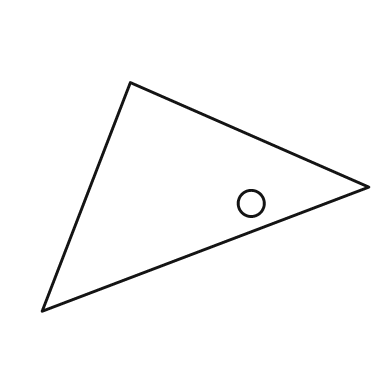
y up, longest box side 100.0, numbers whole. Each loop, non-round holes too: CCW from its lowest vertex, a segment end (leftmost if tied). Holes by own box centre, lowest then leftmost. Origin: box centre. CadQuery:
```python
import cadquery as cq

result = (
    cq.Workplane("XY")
    .moveTo(-50.0, -35.0)
    .lineTo(50.0, 3.0)
    .lineTo(-23.0, 35.0)
    .close()
    .moveTo(14.0, -2.0)
    .circle(4.0)
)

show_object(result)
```